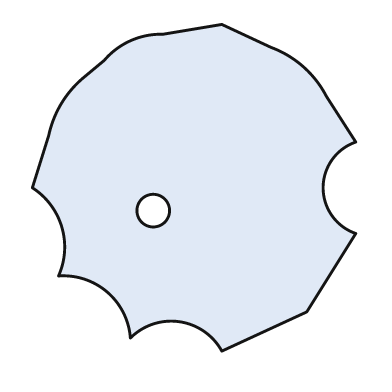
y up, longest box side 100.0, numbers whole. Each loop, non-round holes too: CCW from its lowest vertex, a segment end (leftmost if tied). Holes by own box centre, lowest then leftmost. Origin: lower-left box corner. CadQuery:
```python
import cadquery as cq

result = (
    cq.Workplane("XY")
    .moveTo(58.0, 0.0)
    .lineTo(84.0, 12.0)
    .lineTo(99.0, 36.0)
    .threePointArc((89.0, 50.0), (99.0, 64.0))
    .lineTo(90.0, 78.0)
    .threePointArc((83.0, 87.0), (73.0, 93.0))
    .lineTo(58.0, 100.0)
    .lineTo(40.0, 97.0)
    .threePointArc((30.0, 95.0), (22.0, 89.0))
    .lineTo(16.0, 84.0)
    .threePointArc((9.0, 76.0), (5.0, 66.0))
    .lineTo(0.0, 50.0)
    .threePointArc((9.0, 38.0), (8.0, 23.0))
    .threePointArc((23.0, 18.0), (30.0, 4.0))
    .threePointArc((45.0, 9.0), (58.0, 0.0))
    .close()
    .moveTo(37.0, 43.0)
    .circle(5.0)
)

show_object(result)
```